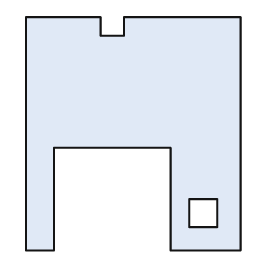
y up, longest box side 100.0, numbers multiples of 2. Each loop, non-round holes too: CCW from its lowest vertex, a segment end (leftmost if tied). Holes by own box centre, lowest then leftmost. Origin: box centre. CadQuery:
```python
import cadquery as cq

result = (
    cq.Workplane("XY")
    .moveTo(-46.0, -50.0)
    .lineTo(-34.0, -50.0)
    .lineTo(-34.0, -6.0)
    .lineTo(16.0, -6.0)
    .lineTo(16.0, -50.0)
    .lineTo(46.0, -50.0)
    .lineTo(46.0, 50.0)
    .lineTo(-4.0, 50.0)
    .lineTo(-4.0, 42.0)
    .lineTo(-14.0, 42.0)
    .lineTo(-14.0, 50.0)
    .lineTo(-46.0, 50.0)
    .close()
    .moveTo(24.0, -40.0)
    .lineTo(36.0, -40.0)
    .lineTo(36.0, -28.0)
    .lineTo(24.0, -28.0)
    .close()
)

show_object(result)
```